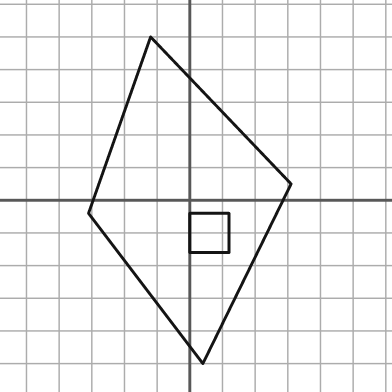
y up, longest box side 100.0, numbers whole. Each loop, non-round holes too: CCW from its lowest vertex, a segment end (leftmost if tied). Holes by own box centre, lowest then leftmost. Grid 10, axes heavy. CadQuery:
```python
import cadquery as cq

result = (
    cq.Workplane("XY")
    .moveTo(4.0, -50.0)
    .lineTo(31.0, 5.0)
    .lineTo(-12.0, 50.0)
    .lineTo(-31.0, -4.0)
    .close()
    .moveTo(0.0, -16.0)
    .lineTo(12.0, -16.0)
    .lineTo(12.0, -4.0)
    .lineTo(0.0, -4.0)
    .close()
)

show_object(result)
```